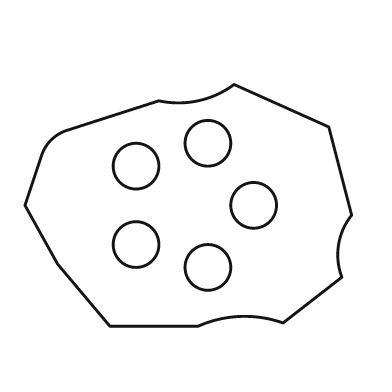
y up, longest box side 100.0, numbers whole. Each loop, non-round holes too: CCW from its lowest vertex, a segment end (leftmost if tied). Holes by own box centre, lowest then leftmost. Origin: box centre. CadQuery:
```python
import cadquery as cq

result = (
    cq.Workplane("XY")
    .moveTo(-24.0, -37.0)
    .lineTo(3.0, -37.0)
    .threePointArc((16.0, -34.0), (29.0, -36.0))
    .lineTo(47.0, -22.0)
    .threePointArc((46.0, -12.0), (50.0, -3.0))
    .lineTo(43.0, 24.0)
    .lineTo(14.0, 37.0)
    .threePointArc((3.0, 32.0), (-9.0, 32.0))
    .lineTo(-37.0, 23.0)
    .threePointArc((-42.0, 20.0), (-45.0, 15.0))
    .lineTo(-50.0, 0.0)
    .lineTo(-40.0, -18.0)
    .close()
    .moveTo(6.0, -19.0)
    .circle(7.0)
    .moveTo(-16.0, -12.0)
    .circle(7.0)
    .moveTo(20.0, 0.0)
    .circle(7.0)
    .moveTo(-16.0, 12.0)
    .circle(7.0)
    .moveTo(6.0, 19.0)
    .circle(7.0)
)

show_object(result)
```